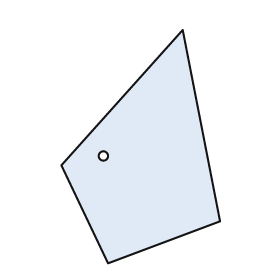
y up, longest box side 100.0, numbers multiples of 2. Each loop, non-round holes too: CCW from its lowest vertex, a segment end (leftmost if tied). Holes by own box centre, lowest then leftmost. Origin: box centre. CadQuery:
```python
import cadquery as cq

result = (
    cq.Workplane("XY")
    .moveTo(-14.0, -50.0)
    .lineTo(34.0, -32.0)
    .lineTo(18.0, 50.0)
    .lineTo(-34.0, -8.0)
    .close()
    .moveTo(-16.0, -4.0)
    .circle(2.0)
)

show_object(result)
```